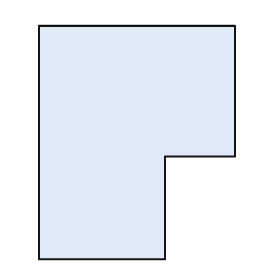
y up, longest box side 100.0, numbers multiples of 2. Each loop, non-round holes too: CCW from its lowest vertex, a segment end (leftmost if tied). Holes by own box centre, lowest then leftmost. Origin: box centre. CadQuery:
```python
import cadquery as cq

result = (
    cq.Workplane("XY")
    .moveTo(-42.0, -50.0)
    .lineTo(12.0, -50.0)
    .lineTo(12.0, -6.0)
    .lineTo(42.0, -6.0)
    .lineTo(42.0, 50.0)
    .lineTo(-42.0, 50.0)
    .close()
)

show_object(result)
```